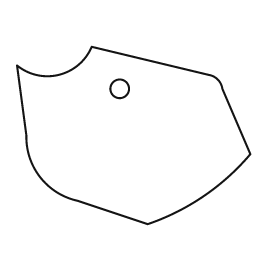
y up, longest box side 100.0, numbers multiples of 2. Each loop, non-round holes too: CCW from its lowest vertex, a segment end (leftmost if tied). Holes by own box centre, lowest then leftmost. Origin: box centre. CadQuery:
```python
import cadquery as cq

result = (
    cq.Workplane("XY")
    .moveTo(6.0, -38.0)
    .threePointArc((30.0, -26.0), (50.0, -8.0))
    .lineTo(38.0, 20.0)
    .threePointArc((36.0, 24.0), (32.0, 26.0))
    .lineTo(-18.0, 38.0)
    .threePointArc((-32.0, 26.0), (-50.0, 30.0))
    .lineTo(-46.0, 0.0)
    .threePointArc((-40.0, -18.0), (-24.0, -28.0))
    .close()
    .moveTo(-6.0, 20.0)
    .circle(4.0)
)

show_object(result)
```